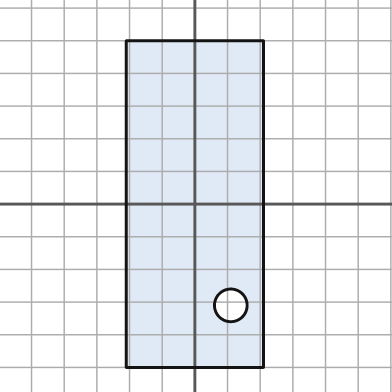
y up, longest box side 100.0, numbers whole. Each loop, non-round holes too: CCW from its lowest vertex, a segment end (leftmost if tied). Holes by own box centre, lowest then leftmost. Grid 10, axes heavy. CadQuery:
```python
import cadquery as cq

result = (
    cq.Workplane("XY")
    .moveTo(-21.0, -50.0)
    .lineTo(21.0, -50.0)
    .lineTo(21.0, 50.0)
    .lineTo(-21.0, 50.0)
    .close()
    .moveTo(11.0, -31.0)
    .circle(5.0)
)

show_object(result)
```